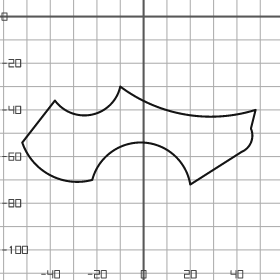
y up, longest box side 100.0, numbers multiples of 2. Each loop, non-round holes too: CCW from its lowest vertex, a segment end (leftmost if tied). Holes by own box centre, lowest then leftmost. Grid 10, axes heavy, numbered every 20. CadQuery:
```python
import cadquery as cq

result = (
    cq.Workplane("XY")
    .moveTo(20.0, -72.0)
    .lineTo(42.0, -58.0)
    .threePointArc((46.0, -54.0), (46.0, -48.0))
    .lineTo(48.0, -40.0)
    .threePointArc((18.0, -42.0), (-10.0, -30.0))
    .threePointArc((-22.0, -42.0), (-38.0, -36.0))
    .lineTo(-52.0, -54.0)
    .threePointArc((-40.0, -68.0), (-22.0, -70.0))
    .threePointArc((0.0, -54.0), (20.0, -72.0))
    .close()
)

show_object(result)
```